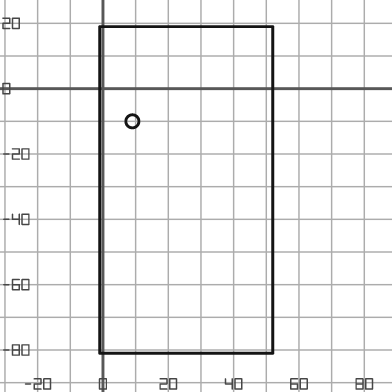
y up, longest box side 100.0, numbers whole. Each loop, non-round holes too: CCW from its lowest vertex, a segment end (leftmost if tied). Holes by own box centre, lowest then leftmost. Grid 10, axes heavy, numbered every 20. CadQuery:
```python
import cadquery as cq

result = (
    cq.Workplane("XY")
    .moveTo(-1.0, -81.0)
    .lineTo(52.0, -81.0)
    .lineTo(52.0, 19.0)
    .lineTo(-1.0, 19.0)
    .close()
    .moveTo(9.0, -10.0)
    .circle(2.0)
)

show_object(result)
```